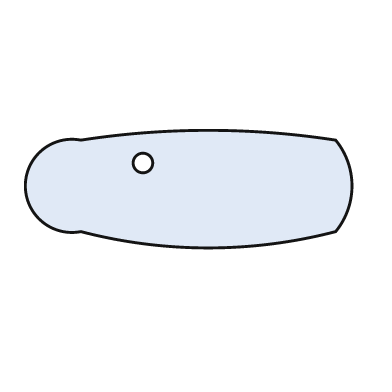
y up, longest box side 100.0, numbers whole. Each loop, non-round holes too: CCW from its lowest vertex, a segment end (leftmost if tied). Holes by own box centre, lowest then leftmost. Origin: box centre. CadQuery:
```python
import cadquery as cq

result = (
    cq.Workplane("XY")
    .moveTo(-33.0, -13.0)
    .threePointArc((6.0, -18.0), (45.0, -13.0))
    .threePointArc((50.0, 1.0), (45.0, 15.0))
    .threePointArc((6.0, 18.0), (-33.0, 15.0))
    .threePointArc((-50.0, 1.0), (-33.0, -13.0))
    .close()
    .moveTo(-14.0, 8.0)
    .circle(3.0)
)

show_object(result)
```